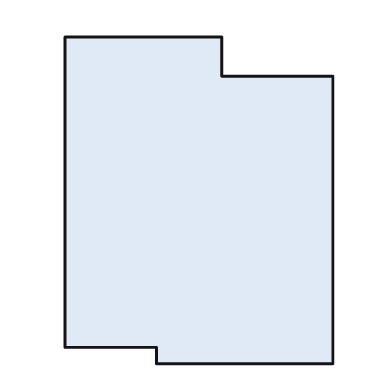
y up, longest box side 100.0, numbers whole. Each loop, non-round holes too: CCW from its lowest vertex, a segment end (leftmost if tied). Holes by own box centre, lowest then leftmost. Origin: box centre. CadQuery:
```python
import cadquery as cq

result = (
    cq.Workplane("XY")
    .moveTo(-13.0, -50.0)
    .lineTo(41.0, -50.0)
    .lineTo(41.0, 38.0)
    .lineTo(7.0, 38.0)
    .lineTo(7.0, 50.0)
    .lineTo(-41.0, 50.0)
    .lineTo(-41.0, -45.0)
    .lineTo(-13.0, -45.0)
    .close()
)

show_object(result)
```